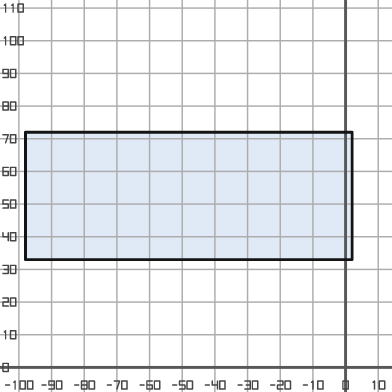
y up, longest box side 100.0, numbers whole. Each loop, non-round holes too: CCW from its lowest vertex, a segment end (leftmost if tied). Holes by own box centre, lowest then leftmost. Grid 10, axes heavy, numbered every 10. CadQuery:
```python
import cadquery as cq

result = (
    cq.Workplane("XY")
    .moveTo(-98.0, 33.0)
    .lineTo(2.0, 33.0)
    .lineTo(2.0, 72.0)
    .lineTo(-98.0, 72.0)
    .close()
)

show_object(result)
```